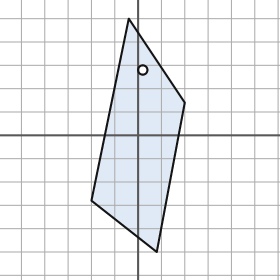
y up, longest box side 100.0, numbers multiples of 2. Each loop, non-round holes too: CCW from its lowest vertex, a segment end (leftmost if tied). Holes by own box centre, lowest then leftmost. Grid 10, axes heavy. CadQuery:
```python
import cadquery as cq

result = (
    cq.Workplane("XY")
    .moveTo(8.0, -50.0)
    .lineTo(20.0, 14.0)
    .lineTo(-4.0, 50.0)
    .lineTo(-20.0, -28.0)
    .close()
    .moveTo(2.0, 28.0)
    .circle(2.0)
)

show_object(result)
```